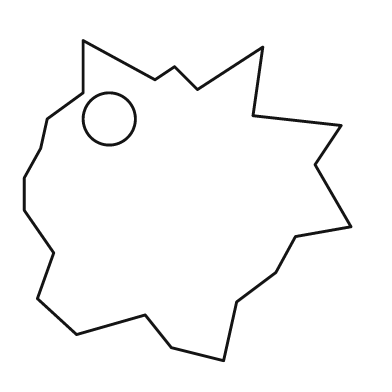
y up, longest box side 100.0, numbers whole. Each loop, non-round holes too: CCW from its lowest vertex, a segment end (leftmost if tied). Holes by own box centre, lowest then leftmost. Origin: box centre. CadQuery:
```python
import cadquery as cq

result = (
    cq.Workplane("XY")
    .moveTo(11.0, -49.0)
    .lineTo(15.0, -31.0)
    .lineTo(27.0, -22.0)
    .lineTo(33.0, -11.0)
    .lineTo(50.0, -8.0)
    .lineTo(39.0, 11.0)
    .lineTo(47.0, 23.0)
    .lineTo(20.0, 26.0)
    .lineTo(23.0, 47.0)
    .lineTo(3.0, 34.0)
    .lineTo(-4.0, 41.0)
    .lineTo(-10.0, 37.0)
    .lineTo(-32.0, 49.0)
    .lineTo(-32.0, 33.0)
    .lineTo(-43.0, 25.0)
    .lineTo(-45.0, 16.0)
    .lineTo(-50.0, 7.0)
    .lineTo(-50.0, -3.0)
    .lineTo(-41.0, -16.0)
    .lineTo(-46.0, -30.0)
    .lineTo(-34.0, -41.0)
    .lineTo(-13.0, -35.0)
    .lineTo(-5.0, -45.0)
    .close()
    .moveTo(-24.0, 25.0)
    .circle(8.0)
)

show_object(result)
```